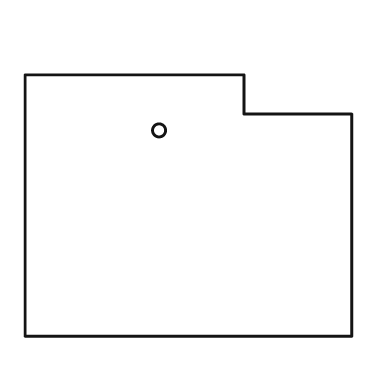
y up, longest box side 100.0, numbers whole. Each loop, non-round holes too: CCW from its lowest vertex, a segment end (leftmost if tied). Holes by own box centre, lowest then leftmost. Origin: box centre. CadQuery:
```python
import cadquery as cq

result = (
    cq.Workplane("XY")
    .moveTo(-50.0, -40.0)
    .lineTo(50.0, -40.0)
    .lineTo(50.0, 28.0)
    .lineTo(17.0, 28.0)
    .lineTo(17.0, 40.0)
    .lineTo(-50.0, 40.0)
    .close()
    .moveTo(-9.0, 23.0)
    .circle(2.0)
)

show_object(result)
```